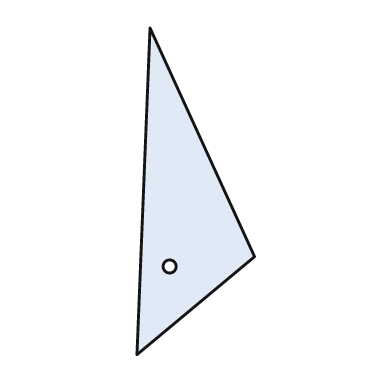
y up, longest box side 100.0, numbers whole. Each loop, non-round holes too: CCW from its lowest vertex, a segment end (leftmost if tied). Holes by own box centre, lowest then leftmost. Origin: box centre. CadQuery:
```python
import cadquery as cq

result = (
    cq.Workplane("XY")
    .moveTo(-18.0, -50.0)
    .lineTo(18.0, -20.0)
    .lineTo(-14.0, 50.0)
    .close()
    .moveTo(-8.0, -23.0)
    .circle(2.0)
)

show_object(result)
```